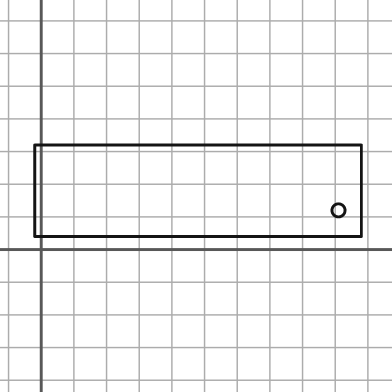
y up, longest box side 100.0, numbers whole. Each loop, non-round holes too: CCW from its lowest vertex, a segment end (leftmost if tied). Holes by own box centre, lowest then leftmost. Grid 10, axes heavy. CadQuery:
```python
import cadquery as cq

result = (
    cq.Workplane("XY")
    .moveTo(-2.0, 4.0)
    .lineTo(98.0, 4.0)
    .lineTo(98.0, 32.0)
    .lineTo(-2.0, 32.0)
    .close()
    .moveTo(91.0, 12.0)
    .circle(2.0)
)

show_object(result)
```